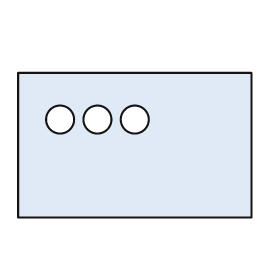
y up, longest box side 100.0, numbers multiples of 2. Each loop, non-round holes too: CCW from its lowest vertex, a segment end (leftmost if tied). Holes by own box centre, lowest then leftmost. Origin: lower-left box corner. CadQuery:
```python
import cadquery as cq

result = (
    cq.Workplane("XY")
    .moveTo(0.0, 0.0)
    .lineTo(100.0, 0.0)
    .lineTo(100.0, 62.0)
    .lineTo(0.0, 62.0)
    .close()
    .moveTo(18.0, 42.0)
    .circle(6.0)
    .moveTo(34.0, 42.0)
    .circle(6.0)
    .moveTo(50.0, 42.0)
    .circle(6.0)
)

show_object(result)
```